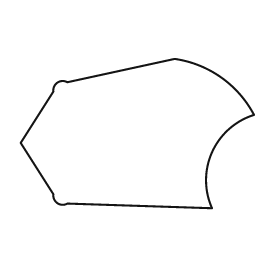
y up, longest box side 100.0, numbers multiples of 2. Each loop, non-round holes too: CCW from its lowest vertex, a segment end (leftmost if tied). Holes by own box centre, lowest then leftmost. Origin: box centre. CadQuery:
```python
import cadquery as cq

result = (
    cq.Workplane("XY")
    .moveTo(32.0, -32.0)
    .threePointArc((32.0, -8.0), (50.0, 8.0))
    .threePointArc((36.0, 24.0), (16.0, 32.0))
    .lineTo(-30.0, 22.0)
    .threePointArc((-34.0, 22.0), (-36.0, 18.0))
    .lineTo(-50.0, -4.0)
    .lineTo(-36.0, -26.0)
    .threePointArc((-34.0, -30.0), (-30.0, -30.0))
    .close()
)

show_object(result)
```